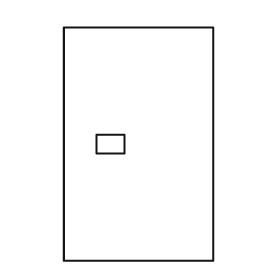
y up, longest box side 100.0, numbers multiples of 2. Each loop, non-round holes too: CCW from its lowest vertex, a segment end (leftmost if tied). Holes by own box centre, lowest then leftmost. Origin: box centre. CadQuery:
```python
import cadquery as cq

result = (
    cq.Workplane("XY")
    .moveTo(-32.0, -50.0)
    .lineTo(32.0, -50.0)
    .lineTo(32.0, 50.0)
    .lineTo(-32.0, 50.0)
    .close()
    .moveTo(-18.0, -4.0)
    .lineTo(-6.0, -4.0)
    .lineTo(-6.0, 4.0)
    .lineTo(-18.0, 4.0)
    .close()
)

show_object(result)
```